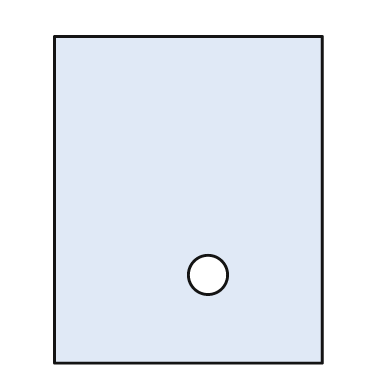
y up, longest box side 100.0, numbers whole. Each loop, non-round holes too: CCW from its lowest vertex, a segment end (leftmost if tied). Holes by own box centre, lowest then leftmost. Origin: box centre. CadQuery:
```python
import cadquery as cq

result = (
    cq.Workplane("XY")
    .moveTo(-41.0, -50.0)
    .lineTo(41.0, -50.0)
    .lineTo(41.0, 50.0)
    .lineTo(-41.0, 50.0)
    .close()
    .moveTo(6.0, -23.0)
    .circle(6.0)
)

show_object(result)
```